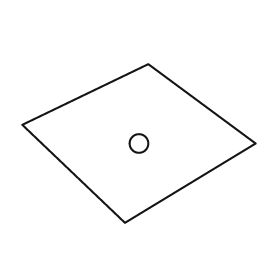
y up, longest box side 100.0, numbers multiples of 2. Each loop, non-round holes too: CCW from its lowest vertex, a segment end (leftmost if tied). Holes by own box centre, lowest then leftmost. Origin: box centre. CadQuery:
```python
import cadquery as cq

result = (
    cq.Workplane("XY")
    .moveTo(-6.0, -34.0)
    .lineTo(50.0, 0.0)
    .lineTo(4.0, 34.0)
    .lineTo(-50.0, 8.0)
    .close()
    .moveTo(0.0, 0.0)
    .circle(4.0)
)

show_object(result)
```